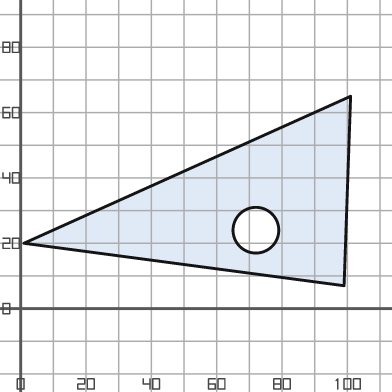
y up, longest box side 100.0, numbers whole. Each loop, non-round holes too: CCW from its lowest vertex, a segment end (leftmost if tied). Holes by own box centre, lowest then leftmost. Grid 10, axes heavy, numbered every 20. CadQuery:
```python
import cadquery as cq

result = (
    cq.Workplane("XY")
    .moveTo(99.0, 7.0)
    .lineTo(101.0, 65.0)
    .lineTo(1.0, 20.0)
    .close()
    .moveTo(72.0, 24.0)
    .circle(7.0)
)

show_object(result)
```